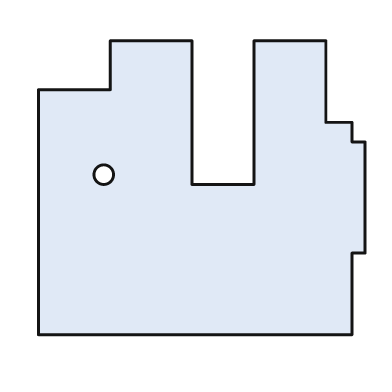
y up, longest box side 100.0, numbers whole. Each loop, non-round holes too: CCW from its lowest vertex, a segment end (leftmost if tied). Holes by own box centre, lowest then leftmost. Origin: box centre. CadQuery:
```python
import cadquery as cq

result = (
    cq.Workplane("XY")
    .moveTo(-50.0, -45.0)
    .lineTo(46.0, -45.0)
    .lineTo(46.0, -20.0)
    .lineTo(50.0, -20.0)
    .lineTo(50.0, 14.0)
    .lineTo(46.0, 14.0)
    .lineTo(46.0, 20.0)
    .lineTo(38.0, 20.0)
    .lineTo(38.0, 45.0)
    .lineTo(16.0, 45.0)
    .lineTo(16.0, 1.0)
    .lineTo(-3.0, 1.0)
    .lineTo(-3.0, 45.0)
    .lineTo(-28.0, 45.0)
    .lineTo(-28.0, 30.0)
    .lineTo(-50.0, 30.0)
    .close()
    .moveTo(-30.0, 4.0)
    .circle(3.0)
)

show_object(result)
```